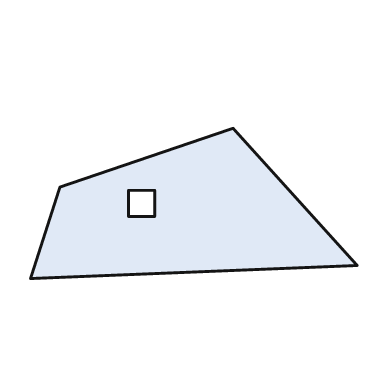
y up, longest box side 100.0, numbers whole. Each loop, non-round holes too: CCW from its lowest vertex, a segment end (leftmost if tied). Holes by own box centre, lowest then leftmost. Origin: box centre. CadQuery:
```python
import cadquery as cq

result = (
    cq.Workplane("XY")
    .moveTo(-50.0, -23.0)
    .lineTo(50.0, -19.0)
    .lineTo(12.0, 23.0)
    .lineTo(-41.0, 5.0)
    .close()
    .moveTo(-20.0, -4.0)
    .lineTo(-12.0, -4.0)
    .lineTo(-12.0, 4.0)
    .lineTo(-20.0, 4.0)
    .close()
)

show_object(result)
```